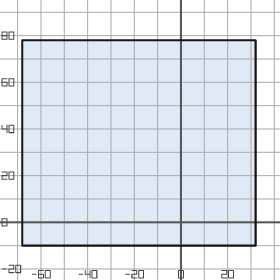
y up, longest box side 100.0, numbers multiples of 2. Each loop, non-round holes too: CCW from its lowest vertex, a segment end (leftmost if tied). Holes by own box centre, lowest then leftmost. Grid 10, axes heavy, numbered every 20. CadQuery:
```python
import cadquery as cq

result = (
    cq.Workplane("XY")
    .moveTo(-68.0, -10.0)
    .lineTo(32.0, -10.0)
    .lineTo(32.0, 78.0)
    .lineTo(-68.0, 78.0)
    .close()
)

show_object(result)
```